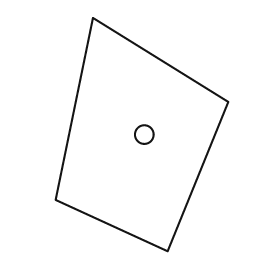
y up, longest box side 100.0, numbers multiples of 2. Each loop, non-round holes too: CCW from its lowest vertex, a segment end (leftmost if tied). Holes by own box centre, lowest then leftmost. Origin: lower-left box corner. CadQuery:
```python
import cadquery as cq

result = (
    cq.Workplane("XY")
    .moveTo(48.0, 0.0)
    .lineTo(74.0, 64.0)
    .lineTo(16.0, 100.0)
    .lineTo(0.0, 22.0)
    .close()
    .moveTo(38.0, 50.0)
    .circle(4.0)
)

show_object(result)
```